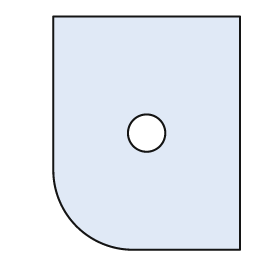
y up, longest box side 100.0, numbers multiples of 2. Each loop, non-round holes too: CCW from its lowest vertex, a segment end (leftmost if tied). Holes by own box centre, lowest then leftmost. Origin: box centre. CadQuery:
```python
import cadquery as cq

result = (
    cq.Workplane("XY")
    .moveTo(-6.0, -50.0)
    .lineTo(40.0, -50.0)
    .lineTo(40.0, 50.0)
    .lineTo(-40.0, 50.0)
    .lineTo(-40.0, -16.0)
    .threePointArc((-30.0, -40.0), (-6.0, -50.0))
    .close()
    .moveTo(0.0, 0.0)
    .circle(8.0)
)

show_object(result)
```